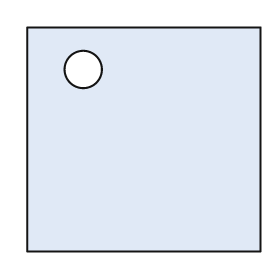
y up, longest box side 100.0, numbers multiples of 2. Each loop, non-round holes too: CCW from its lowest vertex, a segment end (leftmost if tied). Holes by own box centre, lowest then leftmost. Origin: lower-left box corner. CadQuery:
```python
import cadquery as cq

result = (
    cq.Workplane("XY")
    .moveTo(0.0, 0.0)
    .lineTo(100.0, 0.0)
    .lineTo(100.0, 96.0)
    .lineTo(0.0, 96.0)
    .close()
    .moveTo(24.0, 78.0)
    .circle(8.0)
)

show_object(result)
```